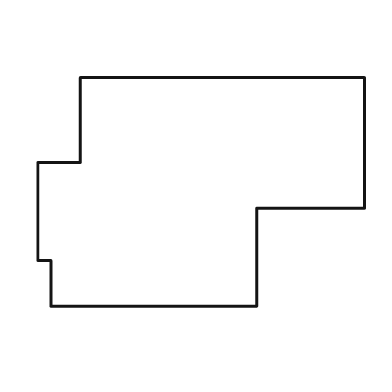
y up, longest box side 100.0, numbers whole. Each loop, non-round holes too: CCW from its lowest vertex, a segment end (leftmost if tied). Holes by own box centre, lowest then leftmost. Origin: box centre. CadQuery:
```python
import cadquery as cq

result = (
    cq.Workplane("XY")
    .moveTo(-46.0, -35.0)
    .lineTo(17.0, -35.0)
    .lineTo(17.0, -5.0)
    .lineTo(50.0, -5.0)
    .lineTo(50.0, 35.0)
    .lineTo(-37.0, 35.0)
    .lineTo(-37.0, 9.0)
    .lineTo(-50.0, 9.0)
    .lineTo(-50.0, -21.0)
    .lineTo(-46.0, -21.0)
    .close()
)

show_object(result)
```